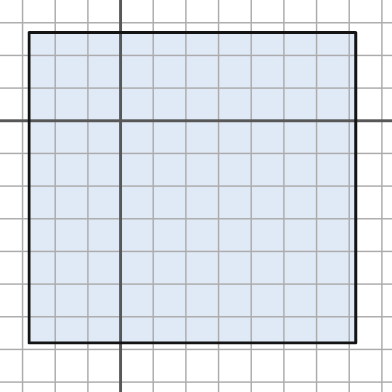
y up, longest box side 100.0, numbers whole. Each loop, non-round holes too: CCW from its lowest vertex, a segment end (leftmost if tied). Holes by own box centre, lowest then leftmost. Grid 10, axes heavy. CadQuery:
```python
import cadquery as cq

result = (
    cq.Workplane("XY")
    .moveTo(-28.0, -68.0)
    .lineTo(72.0, -68.0)
    .lineTo(72.0, 27.0)
    .lineTo(-28.0, 27.0)
    .close()
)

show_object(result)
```